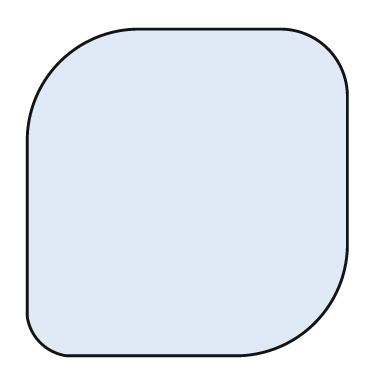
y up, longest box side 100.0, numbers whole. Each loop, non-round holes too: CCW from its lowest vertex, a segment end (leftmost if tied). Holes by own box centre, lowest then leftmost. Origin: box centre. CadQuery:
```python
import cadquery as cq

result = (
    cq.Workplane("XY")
    .moveTo(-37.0, -50.0)
    .lineTo(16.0, -50.0)
    .threePointArc((39.0, -40.0), (49.0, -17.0))
    .lineTo(49.0, 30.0)
    .threePointArc((43.0, 44.0), (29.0, 50.0))
    .lineTo(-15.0, 50.0)
    .threePointArc((-39.0, 40.0), (-49.0, 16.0))
    .lineTo(-49.0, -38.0)
    .threePointArc((-45.0, -46.0), (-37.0, -50.0))
    .close()
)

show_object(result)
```